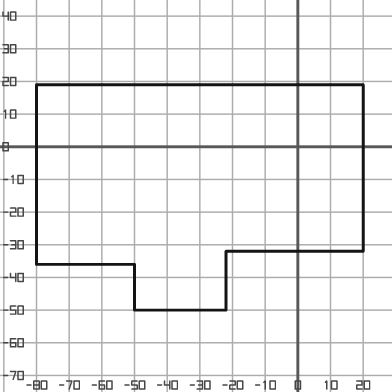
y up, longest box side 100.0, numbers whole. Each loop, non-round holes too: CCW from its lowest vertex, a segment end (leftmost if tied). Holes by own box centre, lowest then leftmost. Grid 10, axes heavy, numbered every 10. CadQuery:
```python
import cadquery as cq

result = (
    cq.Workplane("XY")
    .moveTo(-50.0, -50.0)
    .lineTo(-22.0, -50.0)
    .lineTo(-22.0, -32.0)
    .lineTo(20.0, -32.0)
    .lineTo(20.0, 19.0)
    .lineTo(-80.0, 19.0)
    .lineTo(-80.0, -36.0)
    .lineTo(-50.0, -36.0)
    .close()
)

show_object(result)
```